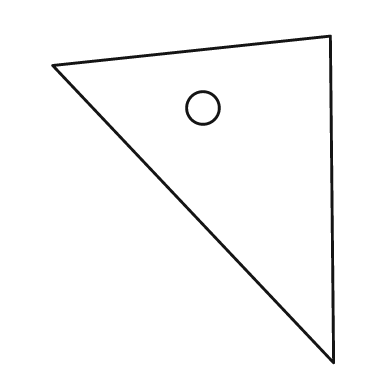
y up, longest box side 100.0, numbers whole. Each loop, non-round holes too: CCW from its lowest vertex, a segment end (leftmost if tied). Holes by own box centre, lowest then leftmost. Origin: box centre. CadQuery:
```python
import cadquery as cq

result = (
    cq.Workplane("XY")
    .moveTo(43.0, -50.0)
    .lineTo(42.0, 50.0)
    .lineTo(-43.0, 41.0)
    .close()
    .moveTo(3.0, 28.0)
    .circle(5.0)
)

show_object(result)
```